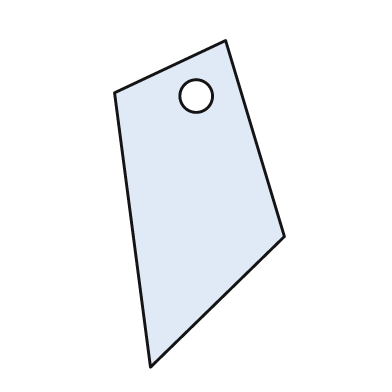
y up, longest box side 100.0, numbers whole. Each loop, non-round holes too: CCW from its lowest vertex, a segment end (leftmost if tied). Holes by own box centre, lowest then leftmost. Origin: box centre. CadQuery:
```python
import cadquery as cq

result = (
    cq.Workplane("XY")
    .moveTo(-15.0, -50.0)
    .lineTo(26.0, -10.0)
    .lineTo(8.0, 50.0)
    .lineTo(-26.0, 34.0)
    .close()
    .moveTo(-1.0, 33.0)
    .circle(5.0)
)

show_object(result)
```